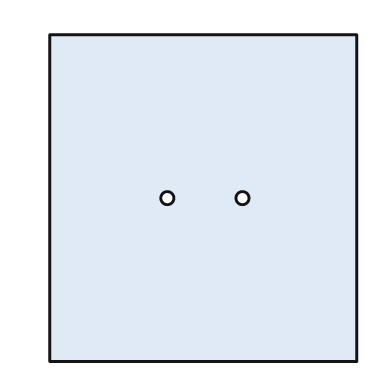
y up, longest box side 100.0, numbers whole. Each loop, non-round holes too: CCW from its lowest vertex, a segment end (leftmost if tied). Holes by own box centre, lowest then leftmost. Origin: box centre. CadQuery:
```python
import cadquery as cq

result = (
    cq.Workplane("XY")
    .moveTo(-47.0, -50.0)
    .lineTo(47.0, -50.0)
    .lineTo(47.0, 50.0)
    .lineTo(-47.0, 50.0)
    .close()
    .moveTo(-11.0, 0.0)
    .circle(2.0)
    .moveTo(12.0, 0.0)
    .circle(2.0)
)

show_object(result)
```